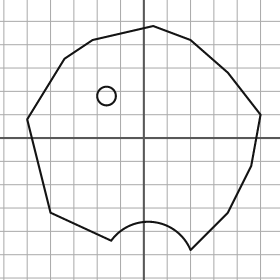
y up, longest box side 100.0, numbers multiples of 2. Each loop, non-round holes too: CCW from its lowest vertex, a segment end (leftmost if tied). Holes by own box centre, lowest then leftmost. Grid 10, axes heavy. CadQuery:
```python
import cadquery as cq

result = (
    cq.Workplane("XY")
    .moveTo(20.0, -48.0)
    .lineTo(36.0, -32.0)
    .lineTo(46.0, -12.0)
    .lineTo(50.0, 10.0)
    .lineTo(36.0, 28.0)
    .lineTo(20.0, 42.0)
    .lineTo(4.0, 48.0)
    .lineTo(-22.0, 42.0)
    .lineTo(-34.0, 34.0)
    .lineTo(-50.0, 8.0)
    .lineTo(-40.0, -32.0)
    .lineTo(-14.0, -44.0)
    .threePointArc((4.0, -36.0), (20.0, -48.0))
    .close()
    .moveTo(-16.0, 18.0)
    .circle(4.0)
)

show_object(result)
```